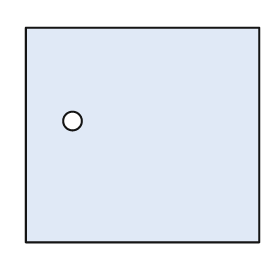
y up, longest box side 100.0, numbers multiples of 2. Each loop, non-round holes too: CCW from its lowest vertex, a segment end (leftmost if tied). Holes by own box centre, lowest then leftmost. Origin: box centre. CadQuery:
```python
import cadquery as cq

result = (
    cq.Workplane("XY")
    .moveTo(-50.0, -46.0)
    .lineTo(50.0, -46.0)
    .lineTo(50.0, 46.0)
    .lineTo(-50.0, 46.0)
    .close()
    .moveTo(-30.0, 6.0)
    .circle(4.0)
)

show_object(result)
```